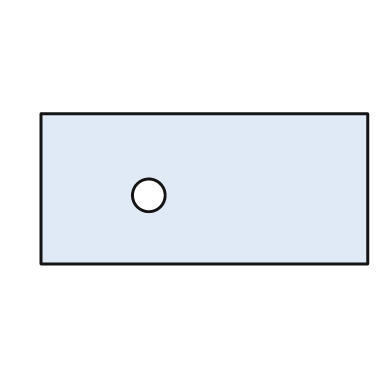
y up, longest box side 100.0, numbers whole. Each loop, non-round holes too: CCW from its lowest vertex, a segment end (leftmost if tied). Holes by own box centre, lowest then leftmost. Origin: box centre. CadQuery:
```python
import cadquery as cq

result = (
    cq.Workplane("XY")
    .moveTo(-50.0, -23.0)
    .lineTo(50.0, -23.0)
    .lineTo(50.0, 23.0)
    .lineTo(-50.0, 23.0)
    .close()
    .moveTo(-17.0, -2.0)
    .circle(5.0)
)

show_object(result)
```